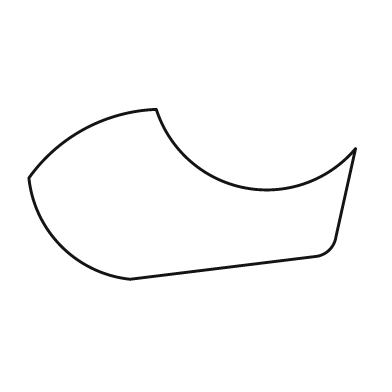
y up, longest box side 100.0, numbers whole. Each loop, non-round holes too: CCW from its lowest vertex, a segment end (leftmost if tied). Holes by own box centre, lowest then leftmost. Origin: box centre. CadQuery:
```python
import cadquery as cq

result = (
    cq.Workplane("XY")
    .moveTo(-19.0, -26.0)
    .lineTo(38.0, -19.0)
    .threePointArc((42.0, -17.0), (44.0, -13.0))
    .lineTo(50.0, 14.0)
    .threePointArc((16.0, 2.0), (-11.0, 26.0))
    .threePointArc((-33.0, 20.0), (-50.0, 5.0))
    .threePointArc((-40.0, -16.0), (-19.0, -26.0))
    .close()
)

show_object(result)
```